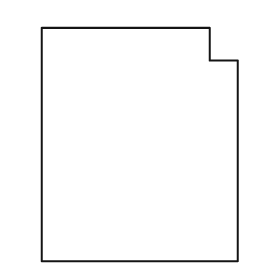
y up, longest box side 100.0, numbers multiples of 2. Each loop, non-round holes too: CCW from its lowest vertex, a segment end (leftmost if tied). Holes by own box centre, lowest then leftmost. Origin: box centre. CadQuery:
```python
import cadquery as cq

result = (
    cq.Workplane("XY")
    .moveTo(-42.0, -50.0)
    .lineTo(42.0, -50.0)
    .lineTo(42.0, 36.0)
    .lineTo(30.0, 36.0)
    .lineTo(30.0, 50.0)
    .lineTo(-42.0, 50.0)
    .close()
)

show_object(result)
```